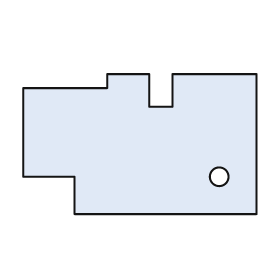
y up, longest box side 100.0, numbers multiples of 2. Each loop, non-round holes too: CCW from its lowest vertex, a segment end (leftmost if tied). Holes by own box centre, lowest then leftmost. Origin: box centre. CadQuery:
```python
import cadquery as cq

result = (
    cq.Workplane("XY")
    .moveTo(-28.0, -30.0)
    .lineTo(50.0, -30.0)
    .lineTo(50.0, 30.0)
    .lineTo(14.0, 30.0)
    .lineTo(14.0, 16.0)
    .lineTo(4.0, 16.0)
    .lineTo(4.0, 30.0)
    .lineTo(-14.0, 30.0)
    .lineTo(-14.0, 24.0)
    .lineTo(-50.0, 24.0)
    .lineTo(-50.0, -14.0)
    .lineTo(-28.0, -14.0)
    .close()
    .moveTo(34.0, -14.0)
    .circle(4.0)
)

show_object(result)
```